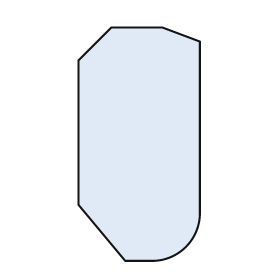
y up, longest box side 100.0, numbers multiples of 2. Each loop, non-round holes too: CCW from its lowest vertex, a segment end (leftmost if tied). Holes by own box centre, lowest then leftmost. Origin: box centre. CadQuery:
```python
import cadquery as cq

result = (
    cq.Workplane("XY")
    .moveTo(-6.0, -50.0)
    .lineTo(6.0, -50.0)
    .threePointArc((20.0, -44.0), (26.0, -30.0))
    .lineTo(26.0, 44.0)
    .lineTo(10.0, 50.0)
    .lineTo(-12.0, 50.0)
    .lineTo(-26.0, 36.0)
    .lineTo(-26.0, -26.0)
    .close()
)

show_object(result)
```